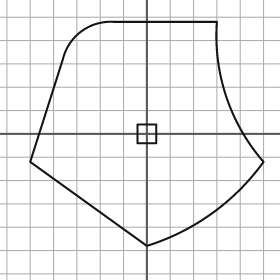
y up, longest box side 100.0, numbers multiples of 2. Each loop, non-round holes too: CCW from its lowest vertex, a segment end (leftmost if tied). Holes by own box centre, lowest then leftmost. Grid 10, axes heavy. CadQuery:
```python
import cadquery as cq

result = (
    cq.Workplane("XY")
    .moveTo(0.0, -48.0)
    .threePointArc((28.0, -34.0), (50.0, -12.0))
    .threePointArc((34.0, 16.0), (30.0, 48.0))
    .lineTo(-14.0, 48.0)
    .threePointArc((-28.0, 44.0), (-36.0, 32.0))
    .lineTo(-50.0, -12.0)
    .close()
    .moveTo(-4.0, -4.0)
    .lineTo(4.0, -4.0)
    .lineTo(4.0, 4.0)
    .lineTo(-4.0, 4.0)
    .close()
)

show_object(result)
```